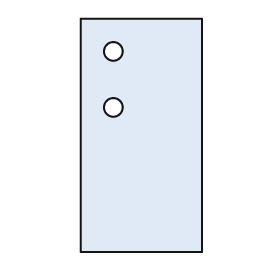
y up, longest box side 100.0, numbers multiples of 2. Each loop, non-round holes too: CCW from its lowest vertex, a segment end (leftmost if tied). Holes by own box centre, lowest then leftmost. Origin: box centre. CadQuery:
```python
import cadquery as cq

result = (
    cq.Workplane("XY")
    .moveTo(-26.0, -50.0)
    .lineTo(26.0, -50.0)
    .lineTo(26.0, 50.0)
    .lineTo(-26.0, 50.0)
    .close()
    .moveTo(-12.0, 12.0)
    .circle(4.0)
    .moveTo(-12.0, 36.0)
    .circle(4.0)
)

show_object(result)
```